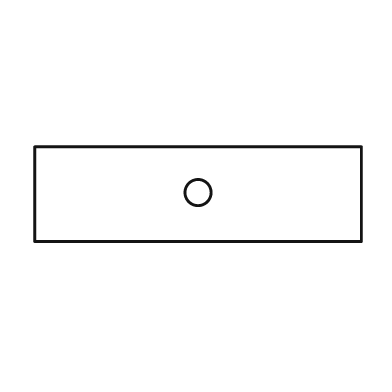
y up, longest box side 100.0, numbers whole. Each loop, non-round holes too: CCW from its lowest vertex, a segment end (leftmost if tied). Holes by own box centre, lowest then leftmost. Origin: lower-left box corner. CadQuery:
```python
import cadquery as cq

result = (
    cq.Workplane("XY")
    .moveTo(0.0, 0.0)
    .lineTo(100.0, 0.0)
    .lineTo(100.0, 29.0)
    .lineTo(0.0, 29.0)
    .close()
    .moveTo(50.0, 15.0)
    .circle(4.0)
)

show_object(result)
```